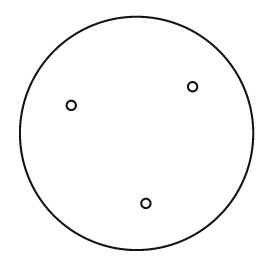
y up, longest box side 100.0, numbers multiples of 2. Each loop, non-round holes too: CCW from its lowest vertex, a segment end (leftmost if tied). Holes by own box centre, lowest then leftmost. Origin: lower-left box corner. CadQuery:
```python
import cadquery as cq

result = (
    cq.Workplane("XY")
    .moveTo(50.0, 50.0)
    .circle(50.0)
    .moveTo(54.0, 20.0)
    .circle(2.0)
    .moveTo(22.0, 62.0)
    .circle(2.0)
    .moveTo(74.0, 70.0)
    .circle(2.0)
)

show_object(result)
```